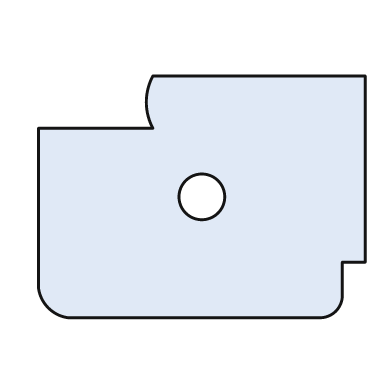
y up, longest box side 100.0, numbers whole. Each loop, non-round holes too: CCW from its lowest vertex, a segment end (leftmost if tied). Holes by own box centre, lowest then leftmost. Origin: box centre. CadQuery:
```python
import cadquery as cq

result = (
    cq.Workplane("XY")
    .moveTo(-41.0, -37.0)
    .lineTo(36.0, -37.0)
    .threePointArc((41.0, -35.0), (43.0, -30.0))
    .lineTo(43.0, -20.0)
    .lineTo(50.0, -20.0)
    .lineTo(50.0, 37.0)
    .lineTo(-15.0, 37.0)
    .threePointArc((-17.0, 29.0), (-15.0, 21.0))
    .lineTo(-50.0, 21.0)
    .lineTo(-50.0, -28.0)
    .threePointArc((-47.0, -34.0), (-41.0, -37.0))
    .close()
    .moveTo(0.0, 0.0)
    .circle(7.0)
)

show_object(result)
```